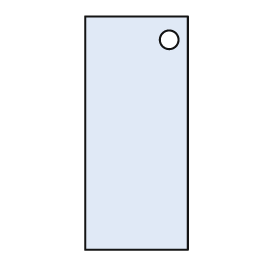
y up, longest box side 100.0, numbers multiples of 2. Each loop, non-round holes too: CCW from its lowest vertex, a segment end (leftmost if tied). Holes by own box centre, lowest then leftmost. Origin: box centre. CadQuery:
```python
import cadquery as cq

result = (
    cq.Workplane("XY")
    .moveTo(-22.0, -50.0)
    .lineTo(22.0, -50.0)
    .lineTo(22.0, 50.0)
    .lineTo(-22.0, 50.0)
    .close()
    .moveTo(14.0, 40.0)
    .circle(4.0)
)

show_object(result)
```